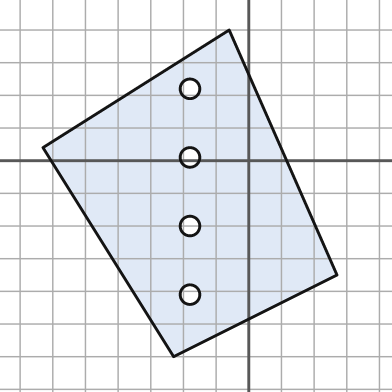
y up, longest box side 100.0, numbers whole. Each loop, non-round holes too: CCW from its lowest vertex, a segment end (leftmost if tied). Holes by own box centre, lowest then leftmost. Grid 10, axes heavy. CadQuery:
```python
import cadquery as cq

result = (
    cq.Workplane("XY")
    .moveTo(-23.0, -60.0)
    .lineTo(27.0, -35.0)
    .lineTo(-6.0, 40.0)
    .lineTo(-63.0, 4.0)
    .close()
    .moveTo(-18.0, -41.0)
    .circle(3.0)
    .moveTo(-18.0, -20.0)
    .circle(3.0)
    .moveTo(-18.0, 1.0)
    .circle(3.0)
    .moveTo(-18.0, 22.0)
    .circle(3.0)
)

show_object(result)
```